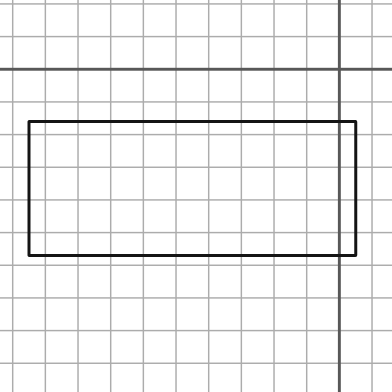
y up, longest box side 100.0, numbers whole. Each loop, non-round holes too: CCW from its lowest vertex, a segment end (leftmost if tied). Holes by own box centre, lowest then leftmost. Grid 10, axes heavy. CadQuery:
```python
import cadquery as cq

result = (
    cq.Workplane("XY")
    .moveTo(-95.0, -57.0)
    .lineTo(5.0, -57.0)
    .lineTo(5.0, -16.0)
    .lineTo(-95.0, -16.0)
    .close()
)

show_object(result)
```